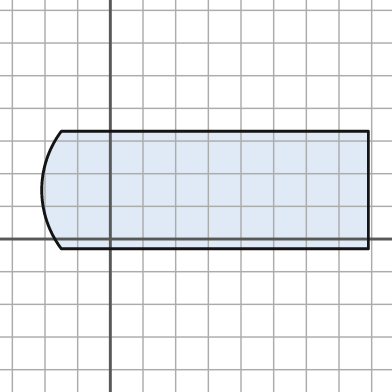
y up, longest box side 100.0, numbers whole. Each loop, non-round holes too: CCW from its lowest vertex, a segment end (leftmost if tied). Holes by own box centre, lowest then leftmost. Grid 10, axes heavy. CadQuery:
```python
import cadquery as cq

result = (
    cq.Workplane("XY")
    .moveTo(-15.0, -3.0)
    .lineTo(79.0, -3.0)
    .lineTo(79.0, 33.0)
    .lineTo(-15.0, 33.0)
    .threePointArc((-21.0, 15.0), (-15.0, -3.0))
    .close()
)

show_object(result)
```